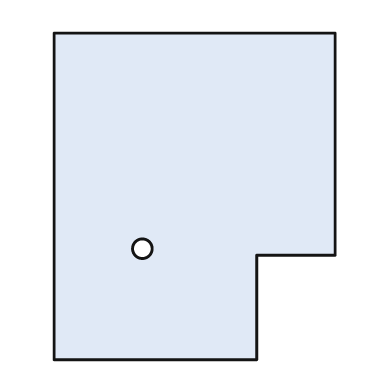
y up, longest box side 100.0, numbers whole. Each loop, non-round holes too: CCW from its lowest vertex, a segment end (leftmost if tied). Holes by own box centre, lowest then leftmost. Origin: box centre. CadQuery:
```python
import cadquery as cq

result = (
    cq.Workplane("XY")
    .moveTo(-43.0, -50.0)
    .lineTo(19.0, -50.0)
    .lineTo(19.0, -18.0)
    .lineTo(43.0, -18.0)
    .lineTo(43.0, 50.0)
    .lineTo(-43.0, 50.0)
    .close()
    .moveTo(-16.0, -16.0)
    .circle(3.0)
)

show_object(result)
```